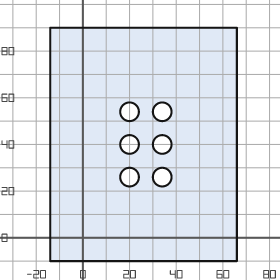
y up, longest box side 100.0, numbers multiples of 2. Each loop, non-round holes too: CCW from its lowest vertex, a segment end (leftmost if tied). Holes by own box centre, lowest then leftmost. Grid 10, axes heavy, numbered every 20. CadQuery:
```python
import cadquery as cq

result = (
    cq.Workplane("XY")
    .moveTo(-14.0, -10.0)
    .lineTo(66.0, -10.0)
    .lineTo(66.0, 90.0)
    .lineTo(-14.0, 90.0)
    .close()
    .moveTo(20.0, 26.0)
    .circle(4.0)
    .moveTo(34.0, 26.0)
    .circle(4.0)
    .moveTo(20.0, 40.0)
    .circle(4.0)
    .moveTo(34.0, 40.0)
    .circle(4.0)
    .moveTo(20.0, 54.0)
    .circle(4.0)
    .moveTo(34.0, 54.0)
    .circle(4.0)
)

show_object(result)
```